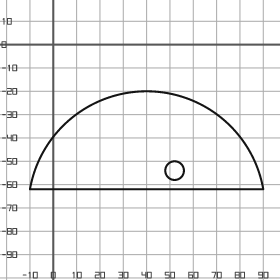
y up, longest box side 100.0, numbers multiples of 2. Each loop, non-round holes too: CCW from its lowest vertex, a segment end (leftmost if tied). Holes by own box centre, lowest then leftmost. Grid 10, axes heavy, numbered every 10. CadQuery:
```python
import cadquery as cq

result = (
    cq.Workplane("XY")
    .moveTo(-10.0, -62.0)
    .lineTo(90.0, -62.0)
    .threePointArc((40.0, -20.0), (-10.0, -62.0))
    .close()
    .moveTo(52.0, -54.0)
    .circle(4.0)
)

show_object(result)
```